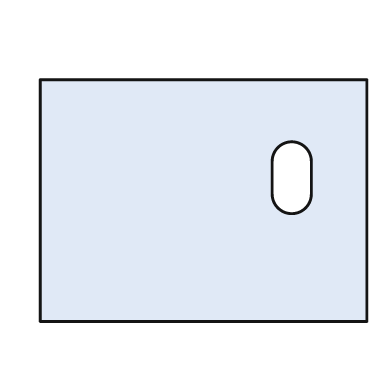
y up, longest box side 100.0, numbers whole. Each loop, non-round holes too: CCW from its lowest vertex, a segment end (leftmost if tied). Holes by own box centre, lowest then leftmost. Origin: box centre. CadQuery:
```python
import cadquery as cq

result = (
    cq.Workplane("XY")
    .moveTo(-50.0, -37.0)
    .lineTo(50.0, -37.0)
    .lineTo(50.0, 37.0)
    .lineTo(-50.0, 37.0)
    .close()
    .moveTo(21.0, 2.0)
    .threePointArc((27.0, -4.0), (33.0, 2.0))
    .lineTo(33.0, 12.0)
    .threePointArc((27.0, 18.0), (21.0, 12.0))
    .close()
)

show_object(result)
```